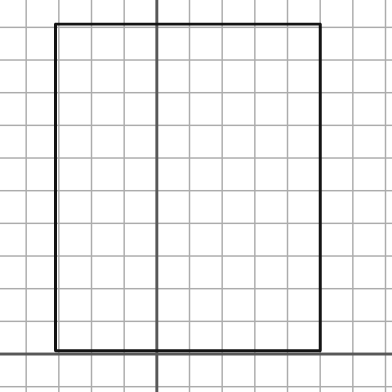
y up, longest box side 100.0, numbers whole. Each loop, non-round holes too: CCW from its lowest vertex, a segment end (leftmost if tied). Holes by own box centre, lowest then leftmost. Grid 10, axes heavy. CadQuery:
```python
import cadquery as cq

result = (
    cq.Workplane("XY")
    .moveTo(-31.0, 1.0)
    .lineTo(50.0, 1.0)
    .lineTo(50.0, 101.0)
    .lineTo(-31.0, 101.0)
    .close()
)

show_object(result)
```